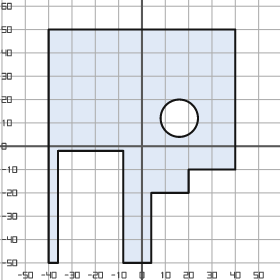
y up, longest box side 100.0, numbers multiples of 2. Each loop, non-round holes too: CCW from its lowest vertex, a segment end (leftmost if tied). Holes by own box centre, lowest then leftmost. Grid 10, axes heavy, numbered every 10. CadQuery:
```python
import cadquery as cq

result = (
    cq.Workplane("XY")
    .moveTo(-40.0, -50.0)
    .lineTo(-36.0, -50.0)
    .lineTo(-36.0, -2.0)
    .lineTo(-8.0, -2.0)
    .lineTo(-8.0, -50.0)
    .lineTo(4.0, -50.0)
    .lineTo(4.0, -20.0)
    .lineTo(20.0, -20.0)
    .lineTo(20.0, -10.0)
    .lineTo(40.0, -10.0)
    .lineTo(40.0, 50.0)
    .lineTo(-40.0, 50.0)
    .close()
    .moveTo(16.0, 12.0)
    .circle(8.0)
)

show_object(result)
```